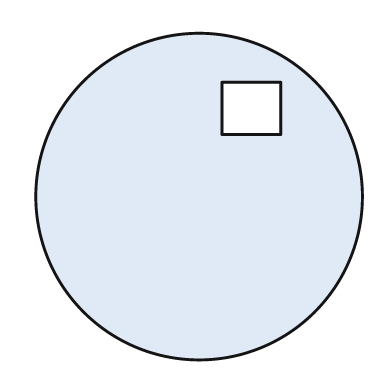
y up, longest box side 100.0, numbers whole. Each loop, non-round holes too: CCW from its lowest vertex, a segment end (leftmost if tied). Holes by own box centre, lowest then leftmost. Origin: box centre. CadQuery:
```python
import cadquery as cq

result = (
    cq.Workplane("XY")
    .moveTo(0.0, 0.0)
    .circle(50.0)
    .moveTo(7.0, 19.0)
    .lineTo(25.0, 19.0)
    .lineTo(25.0, 35.0)
    .lineTo(7.0, 35.0)
    .close()
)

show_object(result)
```